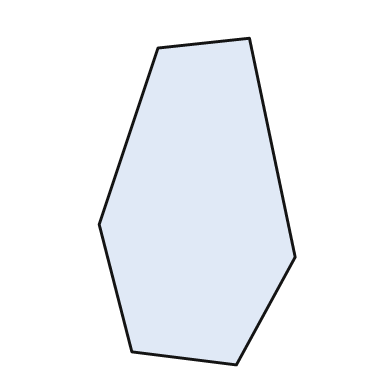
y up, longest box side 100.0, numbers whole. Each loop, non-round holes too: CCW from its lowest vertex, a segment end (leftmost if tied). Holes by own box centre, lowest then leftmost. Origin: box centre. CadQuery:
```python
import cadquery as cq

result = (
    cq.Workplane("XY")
    .moveTo(12.0, -50.0)
    .lineTo(30.0, -17.0)
    .lineTo(16.0, 50.0)
    .lineTo(-12.0, 47.0)
    .lineTo(-30.0, -7.0)
    .lineTo(-20.0, -46.0)
    .close()
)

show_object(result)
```